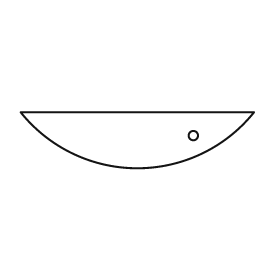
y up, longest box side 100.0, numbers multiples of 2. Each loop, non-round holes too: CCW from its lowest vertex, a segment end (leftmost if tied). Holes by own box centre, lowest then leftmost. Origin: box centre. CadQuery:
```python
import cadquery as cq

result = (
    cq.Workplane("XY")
    .moveTo(-50.0, 12.0)
    .threePointArc((0.0, -12.0), (50.0, 12.0))
    .close()
    .moveTo(24.0, 2.0)
    .circle(2.0)
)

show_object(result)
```